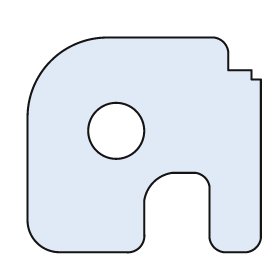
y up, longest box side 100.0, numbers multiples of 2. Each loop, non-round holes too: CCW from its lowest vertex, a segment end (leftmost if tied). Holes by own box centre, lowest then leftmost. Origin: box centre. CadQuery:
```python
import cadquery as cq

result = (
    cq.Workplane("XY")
    .moveTo(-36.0, -46.0)
    .lineTo(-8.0, -46.0)
    .threePointArc((-2.0, -44.0), (0.0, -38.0))
    .lineTo(0.0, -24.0)
    .threePointArc((4.0, -16.0), (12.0, -12.0))
    .lineTo(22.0, -12.0)
    .threePointArc((26.0, -14.0), (28.0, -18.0))
    .lineTo(28.0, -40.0)
    .threePointArc((30.0, -44.0), (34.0, -46.0))
    .lineTo(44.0, -46.0)
    .threePointArc((48.0, -44.0), (50.0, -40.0))
    .lineTo(50.0, 28.0)
    .lineTo(46.0, 28.0)
    .lineTo(46.0, 32.0)
    .lineTo(36.0, 32.0)
    .lineTo(36.0, 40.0)
    .threePointArc((34.0, 44.0), (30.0, 46.0))
    .lineTo(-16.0, 46.0)
    .threePointArc((-40.0, 36.0), (-50.0, 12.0))
    .lineTo(-50.0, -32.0)
    .threePointArc((-46.0, -42.0), (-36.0, -46.0))
    .close()
    .moveTo(-12.0, 6.0)
    .circle(12.0)
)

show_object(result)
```